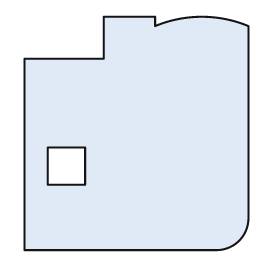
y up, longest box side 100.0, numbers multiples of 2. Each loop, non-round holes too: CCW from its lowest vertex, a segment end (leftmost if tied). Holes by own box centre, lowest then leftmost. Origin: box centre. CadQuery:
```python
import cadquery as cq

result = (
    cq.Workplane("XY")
    .moveTo(-48.0, -50.0)
    .lineTo(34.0, -50.0)
    .threePointArc((44.0, -46.0), (48.0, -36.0))
    .lineTo(48.0, 46.0)
    .threePointArc((28.0, 50.0), (8.0, 46.0))
    .lineTo(8.0, 50.0)
    .lineTo(-14.0, 50.0)
    .lineTo(-14.0, 32.0)
    .lineTo(-48.0, 32.0)
    .close()
    .moveTo(-38.0, -22.0)
    .lineTo(-22.0, -22.0)
    .lineTo(-22.0, -6.0)
    .lineTo(-38.0, -6.0)
    .close()
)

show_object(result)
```